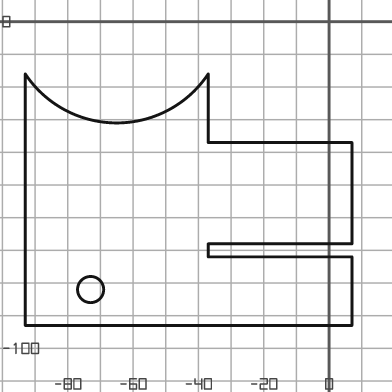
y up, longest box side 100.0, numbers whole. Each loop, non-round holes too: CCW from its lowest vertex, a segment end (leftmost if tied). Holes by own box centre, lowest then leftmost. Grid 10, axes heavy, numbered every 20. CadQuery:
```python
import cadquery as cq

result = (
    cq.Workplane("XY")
    .moveTo(-93.0, -93.0)
    .lineTo(7.0, -93.0)
    .lineTo(7.0, -72.0)
    .lineTo(-37.0, -72.0)
    .lineTo(-37.0, -68.0)
    .lineTo(7.0, -68.0)
    .lineTo(7.0, -37.0)
    .lineTo(-37.0, -37.0)
    .lineTo(-37.0, -16.0)
    .threePointArc((-65.0, -31.0), (-93.0, -16.0))
    .close()
    .moveTo(-73.0, -82.0)
    .circle(4.0)
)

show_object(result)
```